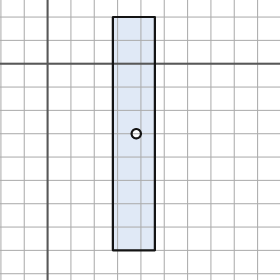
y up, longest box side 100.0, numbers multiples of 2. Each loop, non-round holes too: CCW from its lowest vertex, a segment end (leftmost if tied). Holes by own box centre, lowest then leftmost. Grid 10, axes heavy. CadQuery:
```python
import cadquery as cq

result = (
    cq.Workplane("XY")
    .moveTo(28.0, -80.0)
    .lineTo(46.0, -80.0)
    .lineTo(46.0, 20.0)
    .lineTo(28.0, 20.0)
    .close()
    .moveTo(38.0, -30.0)
    .circle(2.0)
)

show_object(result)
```